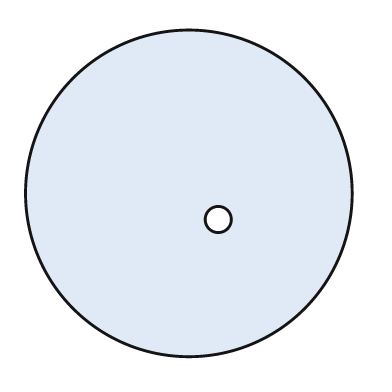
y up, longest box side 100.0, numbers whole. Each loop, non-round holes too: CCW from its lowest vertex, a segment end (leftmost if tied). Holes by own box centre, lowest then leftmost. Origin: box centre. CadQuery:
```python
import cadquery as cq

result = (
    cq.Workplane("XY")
    .moveTo(0.0, 0.0)
    .circle(50.0)
    .moveTo(9.0, -8.0)
    .circle(4.0)
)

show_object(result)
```